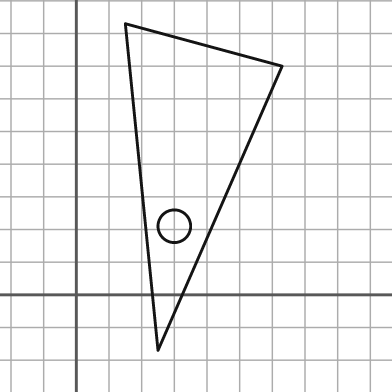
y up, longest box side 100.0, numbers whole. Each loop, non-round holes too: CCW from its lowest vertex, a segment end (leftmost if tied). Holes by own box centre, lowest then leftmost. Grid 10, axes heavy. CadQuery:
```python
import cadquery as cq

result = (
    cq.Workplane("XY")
    .moveTo(25.0, -17.0)
    .lineTo(63.0, 70.0)
    .lineTo(15.0, 83.0)
    .close()
    .moveTo(30.0, 21.0)
    .circle(5.0)
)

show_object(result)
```